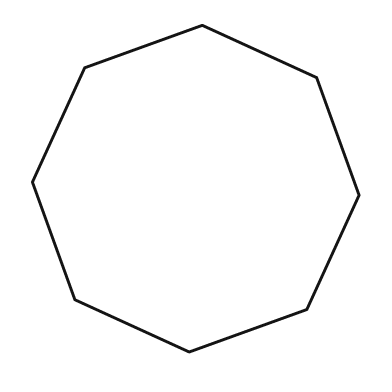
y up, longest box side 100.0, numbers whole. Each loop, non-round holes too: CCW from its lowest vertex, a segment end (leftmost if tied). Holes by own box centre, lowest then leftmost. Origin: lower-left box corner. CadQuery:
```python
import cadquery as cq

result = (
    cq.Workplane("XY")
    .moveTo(48.0, 0.0)
    .lineTo(84.0, 13.0)
    .lineTo(100.0, 48.0)
    .lineTo(87.0, 84.0)
    .lineTo(52.0, 100.0)
    .lineTo(16.0, 87.0)
    .lineTo(0.0, 52.0)
    .lineTo(13.0, 16.0)
    .close()
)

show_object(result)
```